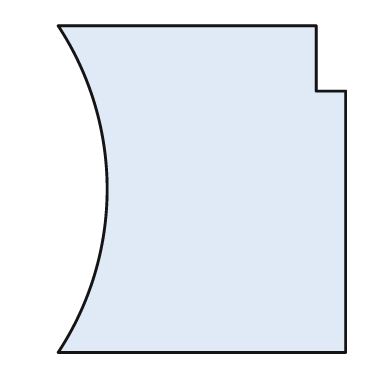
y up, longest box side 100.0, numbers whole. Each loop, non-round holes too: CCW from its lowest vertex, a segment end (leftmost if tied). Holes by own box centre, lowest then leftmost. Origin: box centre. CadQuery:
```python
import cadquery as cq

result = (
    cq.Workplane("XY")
    .moveTo(-44.0, -50.0)
    .lineTo(44.0, -50.0)
    .lineTo(44.0, 30.0)
    .lineTo(35.0, 30.0)
    .lineTo(35.0, 50.0)
    .lineTo(-44.0, 50.0)
    .threePointArc((-29.0, 0.0), (-44.0, -50.0))
    .close()
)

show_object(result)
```